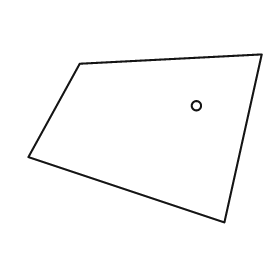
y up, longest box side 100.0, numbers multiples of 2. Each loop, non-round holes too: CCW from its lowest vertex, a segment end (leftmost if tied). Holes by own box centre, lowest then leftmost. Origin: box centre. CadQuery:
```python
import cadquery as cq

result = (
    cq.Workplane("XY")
    .moveTo(34.0, -36.0)
    .lineTo(50.0, 36.0)
    .lineTo(-28.0, 32.0)
    .lineTo(-50.0, -8.0)
    .close()
    .moveTo(22.0, 14.0)
    .circle(2.0)
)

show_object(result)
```